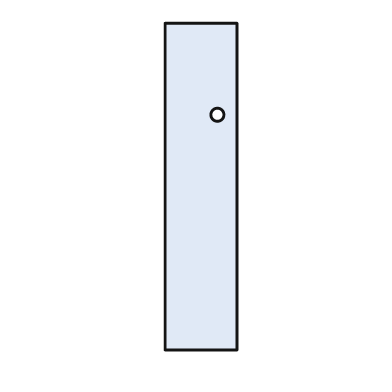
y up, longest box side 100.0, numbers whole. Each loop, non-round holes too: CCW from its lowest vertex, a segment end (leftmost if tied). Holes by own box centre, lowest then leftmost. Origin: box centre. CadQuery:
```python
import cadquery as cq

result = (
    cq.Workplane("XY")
    .moveTo(-11.0, -50.0)
    .lineTo(11.0, -50.0)
    .lineTo(11.0, 50.0)
    .lineTo(-11.0, 50.0)
    .close()
    .moveTo(5.0, 22.0)
    .circle(2.0)
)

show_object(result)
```